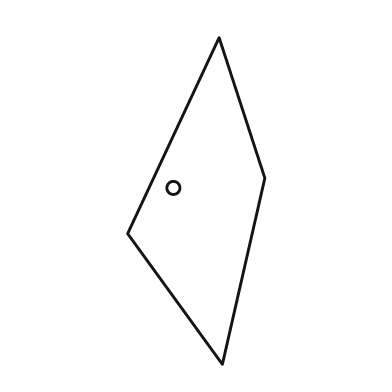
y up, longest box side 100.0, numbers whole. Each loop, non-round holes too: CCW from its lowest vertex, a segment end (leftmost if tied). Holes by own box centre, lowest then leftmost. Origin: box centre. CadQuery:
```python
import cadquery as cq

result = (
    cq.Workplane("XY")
    .moveTo(8.0, -50.0)
    .lineTo(21.0, 7.0)
    .lineTo(7.0, 50.0)
    .lineTo(-21.0, -10.0)
    .close()
    .moveTo(-7.0, 4.0)
    .circle(2.0)
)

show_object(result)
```